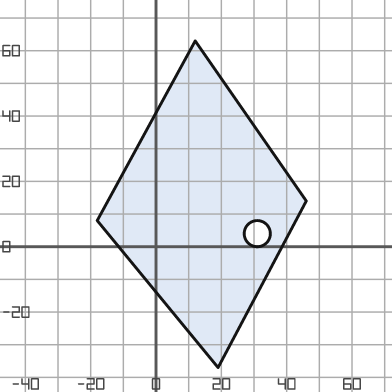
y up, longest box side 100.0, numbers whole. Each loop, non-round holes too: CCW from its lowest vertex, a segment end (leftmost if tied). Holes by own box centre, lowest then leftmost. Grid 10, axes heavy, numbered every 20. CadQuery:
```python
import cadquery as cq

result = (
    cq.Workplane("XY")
    .moveTo(19.0, -37.0)
    .lineTo(46.0, 14.0)
    .lineTo(12.0, 63.0)
    .lineTo(-18.0, 8.0)
    .close()
    .moveTo(31.0, 4.0)
    .circle(4.0)
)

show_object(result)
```